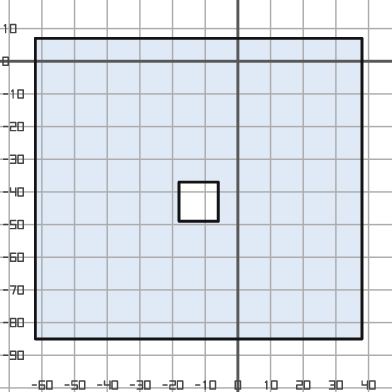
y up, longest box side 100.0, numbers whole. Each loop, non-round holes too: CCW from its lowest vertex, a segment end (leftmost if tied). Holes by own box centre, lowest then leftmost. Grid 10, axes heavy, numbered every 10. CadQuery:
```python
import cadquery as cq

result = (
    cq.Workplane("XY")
    .moveTo(-62.0, -85.0)
    .lineTo(38.0, -85.0)
    .lineTo(38.0, 7.0)
    .lineTo(-62.0, 7.0)
    .close()
    .moveTo(-18.0, -49.0)
    .lineTo(-6.0, -49.0)
    .lineTo(-6.0, -37.0)
    .lineTo(-18.0, -37.0)
    .close()
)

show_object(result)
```